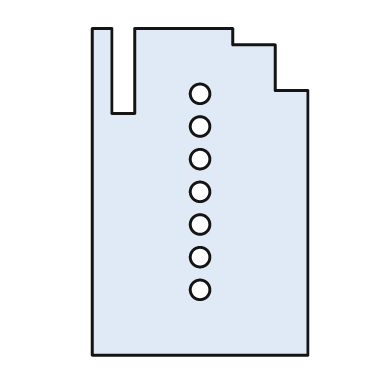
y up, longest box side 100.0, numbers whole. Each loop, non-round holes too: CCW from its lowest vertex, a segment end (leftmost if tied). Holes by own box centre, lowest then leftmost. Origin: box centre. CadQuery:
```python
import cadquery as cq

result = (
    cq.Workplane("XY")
    .moveTo(-33.0, -50.0)
    .lineTo(33.0, -50.0)
    .lineTo(33.0, 31.0)
    .lineTo(23.0, 31.0)
    .lineTo(23.0, 45.0)
    .lineTo(10.0, 45.0)
    .lineTo(10.0, 50.0)
    .lineTo(-20.0, 50.0)
    .lineTo(-20.0, 24.0)
    .lineTo(-27.0, 24.0)
    .lineTo(-27.0, 50.0)
    .lineTo(-33.0, 50.0)
    .close()
    .moveTo(0.0, -30.0)
    .circle(3.0)
    .moveTo(0.0, -20.0)
    .circle(3.0)
    .moveTo(0.0, -10.0)
    .circle(3.0)
    .moveTo(0.0, 0.0)
    .circle(3.0)
    .moveTo(0.0, 10.0)
    .circle(3.0)
    .moveTo(0.0, 20.0)
    .circle(3.0)
    .moveTo(0.0, 30.0)
    .circle(3.0)
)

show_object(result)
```